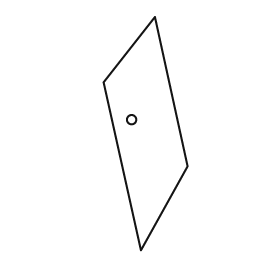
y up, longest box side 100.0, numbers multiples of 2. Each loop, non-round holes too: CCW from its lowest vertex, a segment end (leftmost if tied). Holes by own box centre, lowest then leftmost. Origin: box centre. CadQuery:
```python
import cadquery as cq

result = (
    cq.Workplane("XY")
    .moveTo(-2.0, -50.0)
    .lineTo(18.0, -14.0)
    .lineTo(4.0, 50.0)
    .lineTo(-18.0, 22.0)
    .close()
    .moveTo(-6.0, 6.0)
    .circle(2.0)
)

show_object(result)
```